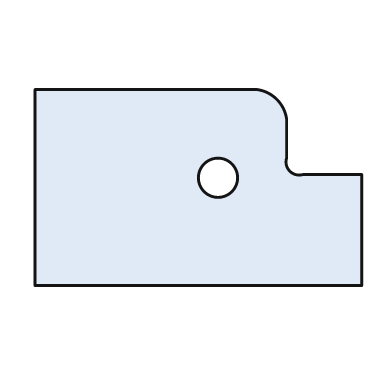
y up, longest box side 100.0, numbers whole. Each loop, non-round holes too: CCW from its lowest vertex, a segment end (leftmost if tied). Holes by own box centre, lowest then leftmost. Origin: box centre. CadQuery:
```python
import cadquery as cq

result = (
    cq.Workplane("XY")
    .moveTo(-50.0, -30.0)
    .lineTo(50.0, -30.0)
    .lineTo(50.0, 4.0)
    .lineTo(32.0, 4.0)
    .threePointArc((28.0, 5.0), (27.0, 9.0))
    .lineTo(27.0, 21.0)
    .threePointArc((24.0, 27.0), (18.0, 30.0))
    .lineTo(-50.0, 30.0)
    .close()
    .moveTo(6.0, 3.0)
    .circle(6.0)
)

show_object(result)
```